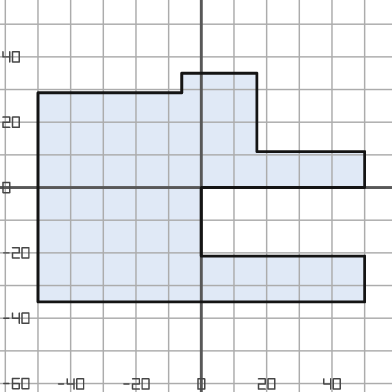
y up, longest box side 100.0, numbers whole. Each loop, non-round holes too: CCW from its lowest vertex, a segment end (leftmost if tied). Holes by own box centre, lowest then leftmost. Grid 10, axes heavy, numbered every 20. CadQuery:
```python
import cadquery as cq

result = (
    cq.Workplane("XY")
    .moveTo(-50.0, -35.0)
    .lineTo(50.0, -35.0)
    .lineTo(50.0, -21.0)
    .lineTo(0.0, -21.0)
    .lineTo(0.0, 0.0)
    .lineTo(50.0, 0.0)
    .lineTo(50.0, 11.0)
    .lineTo(17.0, 11.0)
    .lineTo(17.0, 35.0)
    .lineTo(-6.0, 35.0)
    .lineTo(-6.0, 29.0)
    .lineTo(-50.0, 29.0)
    .close()
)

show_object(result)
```